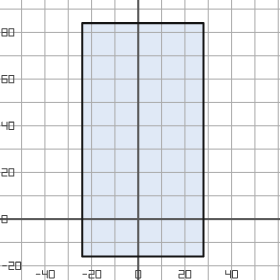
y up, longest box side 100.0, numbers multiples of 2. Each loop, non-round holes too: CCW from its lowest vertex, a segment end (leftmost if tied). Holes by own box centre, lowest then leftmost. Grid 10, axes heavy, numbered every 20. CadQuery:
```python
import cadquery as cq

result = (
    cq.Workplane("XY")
    .moveTo(-24.0, -16.0)
    .lineTo(28.0, -16.0)
    .lineTo(28.0, 84.0)
    .lineTo(-24.0, 84.0)
    .close()
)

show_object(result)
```